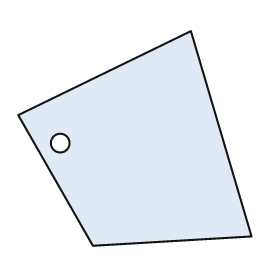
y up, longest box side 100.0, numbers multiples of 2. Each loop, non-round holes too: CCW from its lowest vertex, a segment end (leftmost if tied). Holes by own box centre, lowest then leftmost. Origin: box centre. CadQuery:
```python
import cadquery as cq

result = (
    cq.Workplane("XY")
    .moveTo(-18.0, -46.0)
    .lineTo(50.0, -42.0)
    .lineTo(24.0, 46.0)
    .lineTo(-50.0, 10.0)
    .close()
    .moveTo(-32.0, -2.0)
    .circle(4.0)
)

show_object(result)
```